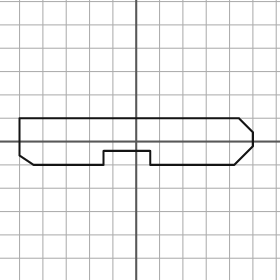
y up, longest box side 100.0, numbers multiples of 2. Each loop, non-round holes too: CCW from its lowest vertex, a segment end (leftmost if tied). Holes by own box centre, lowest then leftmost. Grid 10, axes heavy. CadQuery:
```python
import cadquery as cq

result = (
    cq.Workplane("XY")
    .moveTo(-44.0, -10.0)
    .lineTo(-14.0, -10.0)
    .lineTo(-14.0, -4.0)
    .lineTo(6.0, -4.0)
    .lineTo(6.0, -10.0)
    .lineTo(42.0, -10.0)
    .lineTo(50.0, -2.0)
    .lineTo(50.0, 4.0)
    .lineTo(44.0, 10.0)
    .lineTo(-50.0, 10.0)
    .lineTo(-50.0, -6.0)
    .close()
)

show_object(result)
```